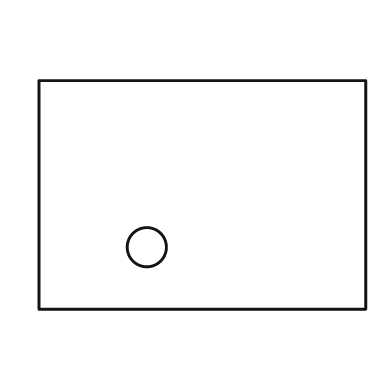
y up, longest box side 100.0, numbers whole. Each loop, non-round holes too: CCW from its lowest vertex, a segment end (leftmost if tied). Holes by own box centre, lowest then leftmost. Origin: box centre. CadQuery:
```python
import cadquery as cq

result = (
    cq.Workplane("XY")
    .moveTo(-50.0, -35.0)
    .lineTo(50.0, -35.0)
    .lineTo(50.0, 35.0)
    .lineTo(-50.0, 35.0)
    .close()
    .moveTo(-17.0, -16.0)
    .circle(6.0)
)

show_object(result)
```